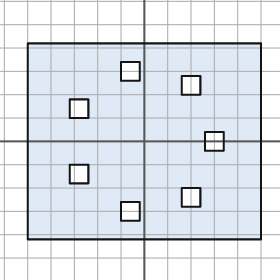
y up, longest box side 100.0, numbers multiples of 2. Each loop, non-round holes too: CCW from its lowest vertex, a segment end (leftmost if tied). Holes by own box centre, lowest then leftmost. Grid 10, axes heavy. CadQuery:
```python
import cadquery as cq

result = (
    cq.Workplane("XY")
    .moveTo(-50.0, -42.0)
    .lineTo(50.0, -42.0)
    .lineTo(50.0, 42.0)
    .lineTo(-50.0, 42.0)
    .close()
    .moveTo(-10.0, -34.0)
    .lineTo(-2.0, -34.0)
    .lineTo(-2.0, -26.0)
    .lineTo(-10.0, -26.0)
    .close()
    .moveTo(16.0, -28.0)
    .lineTo(24.0, -28.0)
    .lineTo(24.0, -20.0)
    .lineTo(16.0, -20.0)
    .close()
    .moveTo(-32.0, -18.0)
    .lineTo(-24.0, -18.0)
    .lineTo(-24.0, -10.0)
    .lineTo(-32.0, -10.0)
    .close()
    .moveTo(26.0, -4.0)
    .lineTo(34.0, -4.0)
    .lineTo(34.0, 4.0)
    .lineTo(26.0, 4.0)
    .close()
    .moveTo(-32.0, 10.0)
    .lineTo(-24.0, 10.0)
    .lineTo(-24.0, 18.0)
    .lineTo(-32.0, 18.0)
    .close()
    .moveTo(16.0, 20.0)
    .lineTo(24.0, 20.0)
    .lineTo(24.0, 28.0)
    .lineTo(16.0, 28.0)
    .close()
    .moveTo(-10.0, 26.0)
    .lineTo(-2.0, 26.0)
    .lineTo(-2.0, 34.0)
    .lineTo(-10.0, 34.0)
    .close()
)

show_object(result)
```